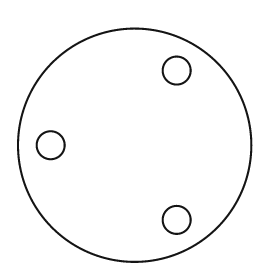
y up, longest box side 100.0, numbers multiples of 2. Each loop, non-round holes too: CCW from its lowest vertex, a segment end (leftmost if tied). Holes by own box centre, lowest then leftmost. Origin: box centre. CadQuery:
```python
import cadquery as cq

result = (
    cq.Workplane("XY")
    .moveTo(0.0, 0.0)
    .circle(50.0)
    .moveTo(18.0, -32.0)
    .circle(6.0)
    .moveTo(-36.0, 0.0)
    .circle(6.0)
    .moveTo(18.0, 32.0)
    .circle(6.0)
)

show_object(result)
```